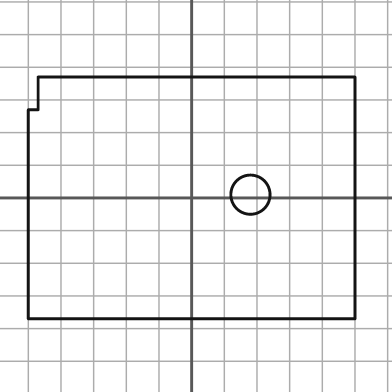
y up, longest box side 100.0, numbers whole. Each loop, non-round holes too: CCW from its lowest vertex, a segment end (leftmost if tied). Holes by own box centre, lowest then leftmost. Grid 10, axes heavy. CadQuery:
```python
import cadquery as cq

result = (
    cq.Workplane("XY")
    .moveTo(-50.0, -37.0)
    .lineTo(50.0, -37.0)
    .lineTo(50.0, 37.0)
    .lineTo(-47.0, 37.0)
    .lineTo(-47.0, 27.0)
    .lineTo(-50.0, 27.0)
    .close()
    .moveTo(18.0, 1.0)
    .circle(6.0)
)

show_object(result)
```